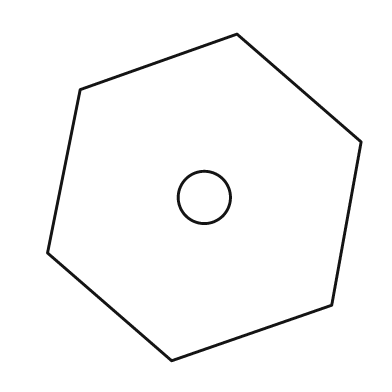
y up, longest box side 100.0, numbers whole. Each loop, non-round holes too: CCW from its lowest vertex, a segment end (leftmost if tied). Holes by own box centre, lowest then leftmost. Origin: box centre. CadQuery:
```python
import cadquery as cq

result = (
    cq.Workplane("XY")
    .moveTo(-10.0, -50.0)
    .lineTo(39.0, -33.0)
    .lineTo(48.0, 17.0)
    .lineTo(10.0, 50.0)
    .lineTo(-38.0, 33.0)
    .lineTo(-48.0, -17.0)
    .close()
    .moveTo(0.0, 0.0)
    .circle(8.0)
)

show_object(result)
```